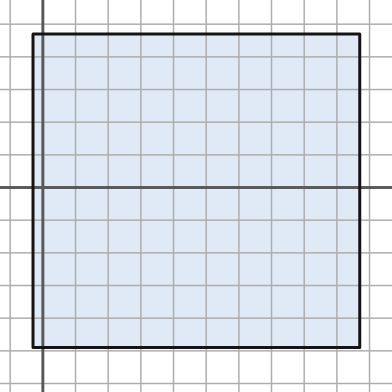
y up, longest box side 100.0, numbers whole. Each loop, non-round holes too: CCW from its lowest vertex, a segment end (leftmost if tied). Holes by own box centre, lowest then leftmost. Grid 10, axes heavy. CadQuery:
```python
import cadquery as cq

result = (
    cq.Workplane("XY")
    .moveTo(-3.0, -49.0)
    .lineTo(97.0, -49.0)
    .lineTo(97.0, 47.0)
    .lineTo(-3.0, 47.0)
    .close()
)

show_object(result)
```